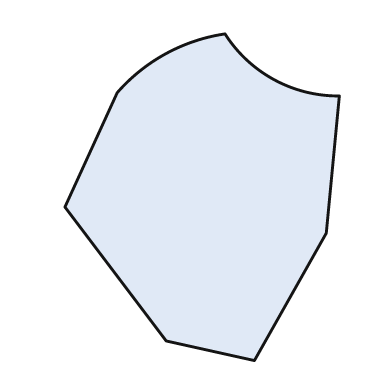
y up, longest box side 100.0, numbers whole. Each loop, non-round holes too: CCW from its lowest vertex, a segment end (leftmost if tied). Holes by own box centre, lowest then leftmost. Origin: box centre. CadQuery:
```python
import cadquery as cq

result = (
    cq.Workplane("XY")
    .moveTo(16.0, -50.0)
    .lineTo(38.0, -11.0)
    .lineTo(42.0, 31.0)
    .threePointArc((22.0, 36.0), (7.0, 50.0))
    .threePointArc((-11.0, 44.0), (-26.0, 32.0))
    .lineTo(-42.0, -3.0)
    .lineTo(-11.0, -44.0)
    .close()
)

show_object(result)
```